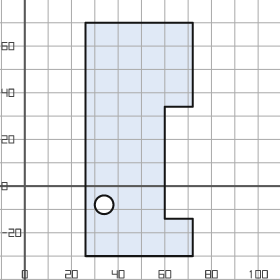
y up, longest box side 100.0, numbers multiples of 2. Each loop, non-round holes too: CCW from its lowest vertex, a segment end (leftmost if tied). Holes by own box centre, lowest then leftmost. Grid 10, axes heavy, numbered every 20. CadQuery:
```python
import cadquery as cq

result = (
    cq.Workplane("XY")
    .moveTo(26.0, -30.0)
    .lineTo(72.0, -30.0)
    .lineTo(72.0, -14.0)
    .lineTo(60.0, -14.0)
    .lineTo(60.0, 34.0)
    .lineTo(72.0, 34.0)
    .lineTo(72.0, 70.0)
    .lineTo(26.0, 70.0)
    .close()
    .moveTo(34.0, -8.0)
    .circle(4.0)
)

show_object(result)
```